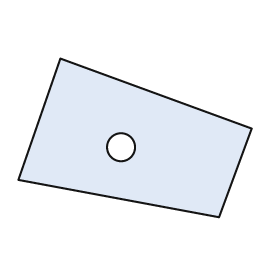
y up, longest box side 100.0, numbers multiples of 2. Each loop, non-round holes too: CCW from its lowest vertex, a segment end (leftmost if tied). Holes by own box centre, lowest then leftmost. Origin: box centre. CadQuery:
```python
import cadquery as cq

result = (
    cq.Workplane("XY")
    .moveTo(36.0, -34.0)
    .lineTo(50.0, 4.0)
    .lineTo(-32.0, 34.0)
    .lineTo(-50.0, -18.0)
    .close()
    .moveTo(-6.0, -4.0)
    .circle(6.0)
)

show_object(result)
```